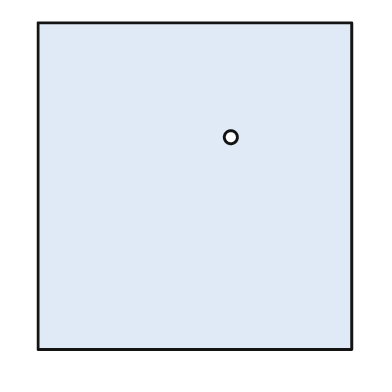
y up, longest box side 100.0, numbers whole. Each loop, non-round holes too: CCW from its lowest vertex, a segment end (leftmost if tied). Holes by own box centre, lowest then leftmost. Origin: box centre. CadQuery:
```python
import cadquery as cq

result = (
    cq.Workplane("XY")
    .moveTo(-48.0, -50.0)
    .lineTo(48.0, -50.0)
    .lineTo(48.0, 50.0)
    .lineTo(-48.0, 50.0)
    .close()
    .moveTo(11.0, 15.0)
    .circle(2.0)
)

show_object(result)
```